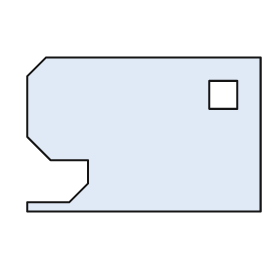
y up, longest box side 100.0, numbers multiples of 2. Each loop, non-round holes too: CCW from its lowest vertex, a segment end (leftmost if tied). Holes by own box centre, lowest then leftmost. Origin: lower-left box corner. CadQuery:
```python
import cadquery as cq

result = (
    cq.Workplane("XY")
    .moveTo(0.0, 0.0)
    .lineTo(100.0, 0.0)
    .lineTo(100.0, 66.0)
    .lineTo(8.0, 66.0)
    .lineTo(0.0, 58.0)
    .lineTo(0.0, 32.0)
    .lineTo(10.0, 22.0)
    .lineTo(26.0, 22.0)
    .lineTo(26.0, 12.0)
    .lineTo(18.0, 4.0)
    .lineTo(0.0, 4.0)
    .close()
    .moveTo(78.0, 44.0)
    .lineTo(90.0, 44.0)
    .lineTo(90.0, 56.0)
    .lineTo(78.0, 56.0)
    .close()
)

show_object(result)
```